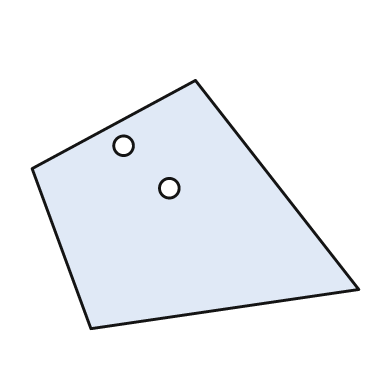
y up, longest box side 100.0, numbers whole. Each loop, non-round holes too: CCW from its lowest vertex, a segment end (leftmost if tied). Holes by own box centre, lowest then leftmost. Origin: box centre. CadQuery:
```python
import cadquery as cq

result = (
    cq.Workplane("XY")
    .moveTo(-32.0, -38.0)
    .lineTo(50.0, -26.0)
    .lineTo(0.0, 38.0)
    .lineTo(-50.0, 11.0)
    .close()
    .moveTo(-8.0, 5.0)
    .circle(3.0)
    .moveTo(-22.0, 18.0)
    .circle(3.0)
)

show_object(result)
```